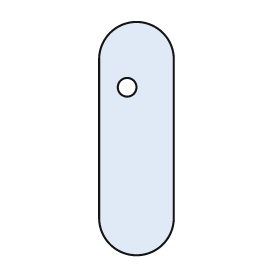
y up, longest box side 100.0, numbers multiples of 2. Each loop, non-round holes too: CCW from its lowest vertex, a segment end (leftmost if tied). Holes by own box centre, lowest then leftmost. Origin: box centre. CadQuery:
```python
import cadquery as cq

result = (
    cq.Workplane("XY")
    .moveTo(-16.0, -34.0)
    .threePointArc((0.0, -50.0), (16.0, -34.0))
    .lineTo(16.0, 34.0)
    .threePointArc((0.0, 50.0), (-16.0, 34.0))
    .close()
    .moveTo(-4.0, 22.0)
    .circle(4.0)
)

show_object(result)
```